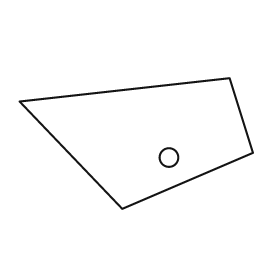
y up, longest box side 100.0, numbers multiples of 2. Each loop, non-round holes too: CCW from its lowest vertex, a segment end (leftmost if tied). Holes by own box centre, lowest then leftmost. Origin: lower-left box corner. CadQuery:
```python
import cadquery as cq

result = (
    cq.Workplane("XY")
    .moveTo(44.0, 0.0)
    .lineTo(100.0, 24.0)
    .lineTo(90.0, 56.0)
    .lineTo(0.0, 46.0)
    .close()
    .moveTo(64.0, 22.0)
    .circle(4.0)
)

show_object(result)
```